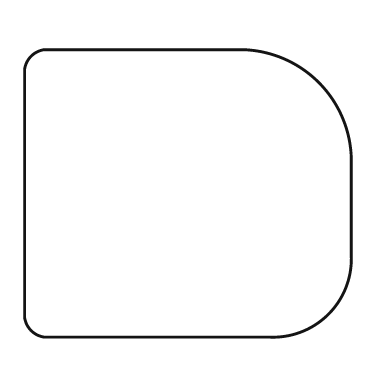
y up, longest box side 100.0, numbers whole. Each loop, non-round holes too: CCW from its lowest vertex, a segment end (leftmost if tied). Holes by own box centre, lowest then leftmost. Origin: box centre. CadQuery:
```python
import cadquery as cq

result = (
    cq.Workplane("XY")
    .moveTo(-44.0, -44.0)
    .lineTo(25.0, -44.0)
    .threePointArc((43.0, -37.0), (50.0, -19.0))
    .lineTo(50.0, 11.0)
    .threePointArc((40.0, 34.0), (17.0, 44.0))
    .lineTo(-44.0, 44.0)
    .threePointArc((-48.0, 42.0), (-50.0, 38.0))
    .lineTo(-50.0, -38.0)
    .threePointArc((-48.0, -42.0), (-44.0, -44.0))
    .close()
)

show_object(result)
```